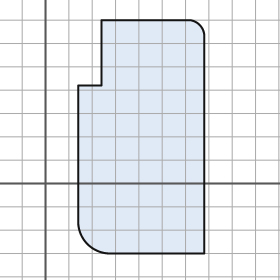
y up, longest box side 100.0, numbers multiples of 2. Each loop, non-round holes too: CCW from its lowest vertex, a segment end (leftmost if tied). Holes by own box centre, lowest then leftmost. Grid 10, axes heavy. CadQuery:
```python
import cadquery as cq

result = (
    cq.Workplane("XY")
    .moveTo(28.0, -30.0)
    .lineTo(68.0, -30.0)
    .lineTo(68.0, 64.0)
    .threePointArc((66.0, 68.0), (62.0, 70.0))
    .lineTo(24.0, 70.0)
    .lineTo(24.0, 42.0)
    .lineTo(14.0, 42.0)
    .lineTo(14.0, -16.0)
    .threePointArc((18.0, -26.0), (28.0, -30.0))
    .close()
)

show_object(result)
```